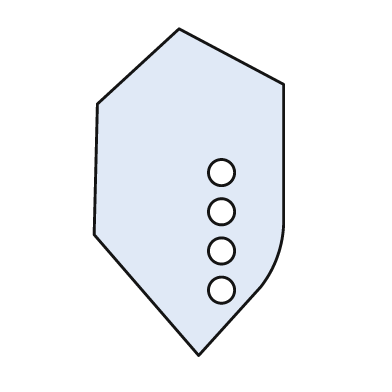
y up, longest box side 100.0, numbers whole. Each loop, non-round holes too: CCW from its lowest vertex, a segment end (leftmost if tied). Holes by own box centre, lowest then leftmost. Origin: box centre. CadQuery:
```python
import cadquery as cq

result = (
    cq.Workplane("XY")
    .moveTo(3.0, -50.0)
    .lineTo(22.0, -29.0)
    .threePointArc((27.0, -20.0), (29.0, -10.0))
    .lineTo(29.0, 33.0)
    .lineTo(-3.0, 50.0)
    .lineTo(-28.0, 27.0)
    .lineTo(-29.0, -13.0)
    .close()
    .moveTo(10.0, -30.0)
    .circle(4.0)
    .moveTo(10.0, -18.0)
    .circle(4.0)
    .moveTo(10.0, -6.0)
    .circle(4.0)
    .moveTo(10.0, 6.0)
    .circle(4.0)
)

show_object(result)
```